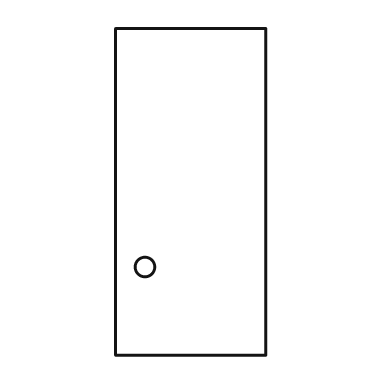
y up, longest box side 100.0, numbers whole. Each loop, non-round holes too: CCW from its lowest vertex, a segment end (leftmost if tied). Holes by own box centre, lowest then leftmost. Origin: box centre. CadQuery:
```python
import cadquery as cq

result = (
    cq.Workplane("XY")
    .moveTo(-23.0, -50.0)
    .lineTo(23.0, -50.0)
    .lineTo(23.0, 50.0)
    .lineTo(-23.0, 50.0)
    .close()
    .moveTo(-14.0, -23.0)
    .circle(3.0)
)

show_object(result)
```